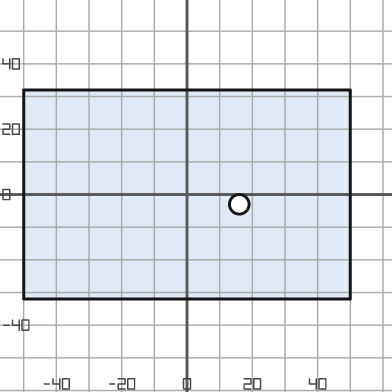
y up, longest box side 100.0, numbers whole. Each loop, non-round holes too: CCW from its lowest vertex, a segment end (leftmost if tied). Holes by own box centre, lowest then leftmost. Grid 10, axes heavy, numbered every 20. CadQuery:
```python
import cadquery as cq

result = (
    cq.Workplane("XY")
    .moveTo(-50.0, -32.0)
    .lineTo(50.0, -32.0)
    .lineTo(50.0, 32.0)
    .lineTo(-50.0, 32.0)
    .close()
    .moveTo(16.0, -3.0)
    .circle(3.0)
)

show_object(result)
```